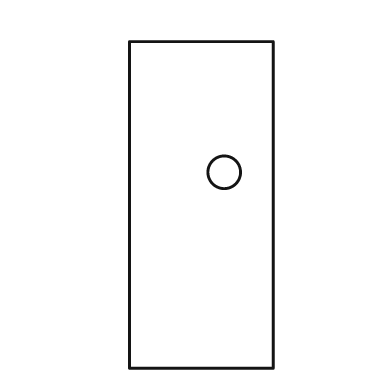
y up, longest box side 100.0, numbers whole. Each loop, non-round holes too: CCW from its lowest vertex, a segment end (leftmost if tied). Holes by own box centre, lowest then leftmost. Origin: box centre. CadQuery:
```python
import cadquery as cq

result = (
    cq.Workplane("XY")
    .moveTo(-22.0, -50.0)
    .lineTo(22.0, -50.0)
    .lineTo(22.0, 50.0)
    .lineTo(-22.0, 50.0)
    .close()
    .moveTo(7.0, 10.0)
    .circle(5.0)
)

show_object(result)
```